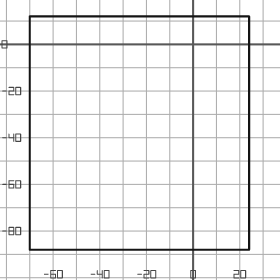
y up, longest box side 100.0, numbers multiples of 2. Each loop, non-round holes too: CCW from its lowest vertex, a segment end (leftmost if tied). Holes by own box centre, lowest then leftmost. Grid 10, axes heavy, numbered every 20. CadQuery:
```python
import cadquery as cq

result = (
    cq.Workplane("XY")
    .moveTo(-70.0, -88.0)
    .lineTo(24.0, -88.0)
    .lineTo(24.0, 12.0)
    .lineTo(-70.0, 12.0)
    .close()
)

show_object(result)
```